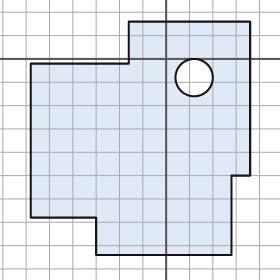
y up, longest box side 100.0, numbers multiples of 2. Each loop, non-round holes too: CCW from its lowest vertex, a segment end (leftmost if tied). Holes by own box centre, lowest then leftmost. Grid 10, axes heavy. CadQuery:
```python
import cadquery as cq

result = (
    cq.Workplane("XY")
    .moveTo(-30.0, -84.0)
    .lineTo(28.0, -84.0)
    .lineTo(28.0, -50.0)
    .lineTo(36.0, -50.0)
    .lineTo(36.0, 16.0)
    .lineTo(-16.0, 16.0)
    .lineTo(-16.0, -2.0)
    .lineTo(-58.0, -2.0)
    .lineTo(-58.0, -68.0)
    .lineTo(-30.0, -68.0)
    .close()
    .moveTo(12.0, -8.0)
    .circle(8.0)
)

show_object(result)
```